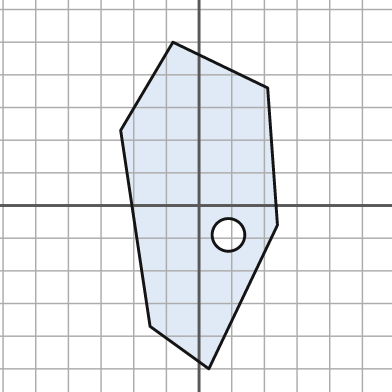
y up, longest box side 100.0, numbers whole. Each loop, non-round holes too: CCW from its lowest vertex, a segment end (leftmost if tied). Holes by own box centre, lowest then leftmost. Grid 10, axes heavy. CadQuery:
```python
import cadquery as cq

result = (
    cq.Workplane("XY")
    .moveTo(3.0, -50.0)
    .lineTo(24.0, -6.0)
    .lineTo(21.0, 36.0)
    .lineTo(-8.0, 50.0)
    .lineTo(-24.0, 23.0)
    .lineTo(-15.0, -37.0)
    .close()
    .moveTo(9.0, -9.0)
    .circle(5.0)
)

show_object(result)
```